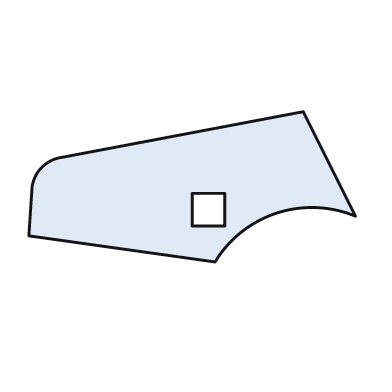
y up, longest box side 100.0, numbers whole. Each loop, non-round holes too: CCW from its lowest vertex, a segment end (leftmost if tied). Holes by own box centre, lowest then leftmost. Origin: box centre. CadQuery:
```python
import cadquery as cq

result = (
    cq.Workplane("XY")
    .moveTo(7.0, -23.0)
    .threePointArc((26.0, -8.0), (50.0, -9.0))
    .lineTo(34.0, 23.0)
    .lineTo(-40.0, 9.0)
    .threePointArc((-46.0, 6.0), (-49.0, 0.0))
    .lineTo(-50.0, -15.0)
    .close()
    .moveTo(0.0, -12.0)
    .lineTo(10.0, -12.0)
    .lineTo(10.0, -2.0)
    .lineTo(0.0, -2.0)
    .close()
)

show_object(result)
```